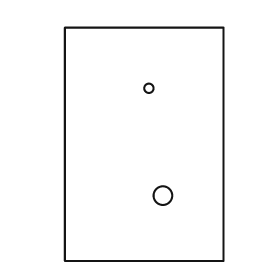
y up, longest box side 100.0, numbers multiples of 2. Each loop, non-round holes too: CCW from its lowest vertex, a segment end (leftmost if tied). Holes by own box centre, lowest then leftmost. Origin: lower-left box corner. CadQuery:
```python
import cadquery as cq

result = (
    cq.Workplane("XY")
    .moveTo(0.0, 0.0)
    .lineTo(68.0, 0.0)
    .lineTo(68.0, 100.0)
    .lineTo(0.0, 100.0)
    .close()
    .moveTo(42.0, 28.0)
    .circle(4.0)
    .moveTo(36.0, 74.0)
    .circle(2.0)
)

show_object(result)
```